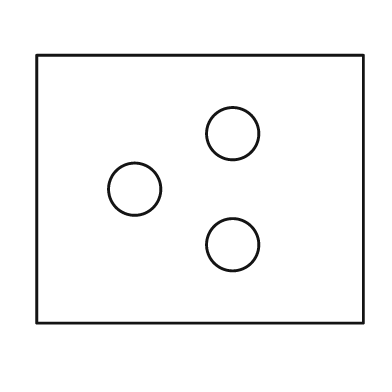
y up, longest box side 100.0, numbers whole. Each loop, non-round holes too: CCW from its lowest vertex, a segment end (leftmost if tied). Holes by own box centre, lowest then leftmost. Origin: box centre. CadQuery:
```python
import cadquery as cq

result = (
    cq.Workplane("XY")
    .moveTo(-50.0, -41.0)
    .lineTo(50.0, -41.0)
    .lineTo(50.0, 41.0)
    .lineTo(-50.0, 41.0)
    .close()
    .moveTo(10.0, -17.0)
    .circle(8.0)
    .moveTo(-20.0, 0.0)
    .circle(8.0)
    .moveTo(10.0, 17.0)
    .circle(8.0)
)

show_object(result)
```